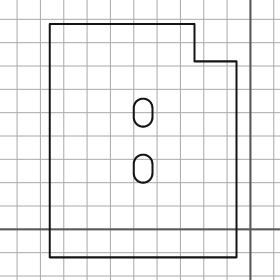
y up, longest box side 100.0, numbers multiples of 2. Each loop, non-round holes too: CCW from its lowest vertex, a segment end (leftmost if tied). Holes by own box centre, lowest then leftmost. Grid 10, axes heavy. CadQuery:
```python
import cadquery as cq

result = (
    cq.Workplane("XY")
    .moveTo(-86.0, -12.0)
    .lineTo(-6.0, -12.0)
    .lineTo(-6.0, 72.0)
    .lineTo(-24.0, 72.0)
    .lineTo(-24.0, 88.0)
    .lineTo(-86.0, 88.0)
    .close()
    .moveTo(-50.0, 24.0)
    .threePointArc((-46.0, 20.0), (-42.0, 24.0))
    .lineTo(-42.0, 28.0)
    .threePointArc((-46.0, 32.0), (-50.0, 28.0))
    .close()
    .moveTo(-50.0, 48.0)
    .threePointArc((-46.0, 44.0), (-42.0, 48.0))
    .lineTo(-42.0, 52.0)
    .threePointArc((-46.0, 56.0), (-50.0, 52.0))
    .close()
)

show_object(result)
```